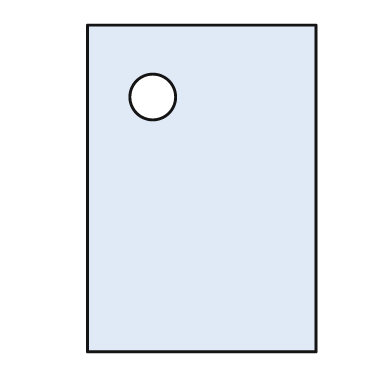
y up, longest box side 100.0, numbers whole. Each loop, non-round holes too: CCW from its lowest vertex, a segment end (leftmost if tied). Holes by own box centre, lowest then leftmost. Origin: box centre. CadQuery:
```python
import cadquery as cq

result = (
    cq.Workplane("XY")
    .moveTo(-35.0, -50.0)
    .lineTo(35.0, -50.0)
    .lineTo(35.0, 50.0)
    .lineTo(-35.0, 50.0)
    .close()
    .moveTo(-15.0, 28.0)
    .circle(7.0)
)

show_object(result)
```